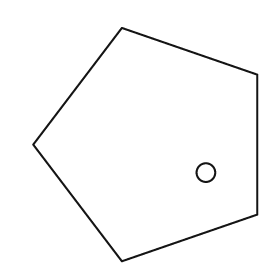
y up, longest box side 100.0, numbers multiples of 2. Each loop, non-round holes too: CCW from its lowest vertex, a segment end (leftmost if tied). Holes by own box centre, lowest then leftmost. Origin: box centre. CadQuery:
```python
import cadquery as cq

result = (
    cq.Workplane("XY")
    .moveTo(-10.0, -50.0)
    .lineTo(48.0, -30.0)
    .lineTo(48.0, 30.0)
    .lineTo(-10.0, 50.0)
    .lineTo(-48.0, 0.0)
    .close()
    .moveTo(26.0, -12.0)
    .circle(4.0)
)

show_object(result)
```